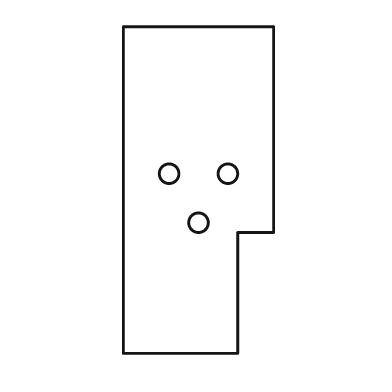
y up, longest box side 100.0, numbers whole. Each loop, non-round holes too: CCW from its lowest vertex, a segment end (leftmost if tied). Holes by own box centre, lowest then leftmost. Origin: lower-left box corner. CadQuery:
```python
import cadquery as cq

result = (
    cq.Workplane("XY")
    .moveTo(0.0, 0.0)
    .lineTo(35.0, 0.0)
    .lineTo(35.0, 37.0)
    .lineTo(46.0, 37.0)
    .lineTo(46.0, 100.0)
    .lineTo(0.0, 100.0)
    .close()
    .moveTo(23.0, 40.0)
    .circle(3.0)
    .moveTo(14.0, 55.0)
    .circle(3.0)
    .moveTo(32.0, 55.0)
    .circle(3.0)
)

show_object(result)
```